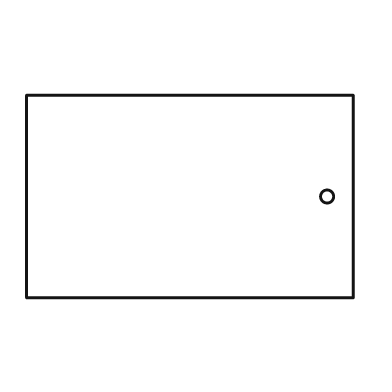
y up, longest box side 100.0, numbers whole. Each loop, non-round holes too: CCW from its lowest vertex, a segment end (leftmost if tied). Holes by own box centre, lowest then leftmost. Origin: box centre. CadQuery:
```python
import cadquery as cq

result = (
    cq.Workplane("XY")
    .moveTo(-50.0, -31.0)
    .lineTo(50.0, -31.0)
    .lineTo(50.0, 31.0)
    .lineTo(-50.0, 31.0)
    .close()
    .moveTo(42.0, 0.0)
    .circle(2.0)
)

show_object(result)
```